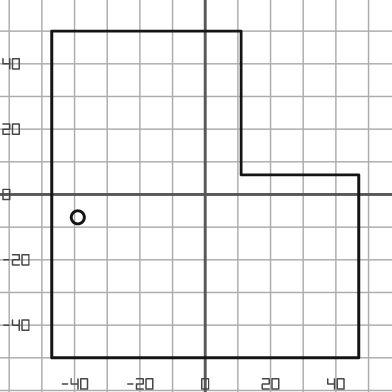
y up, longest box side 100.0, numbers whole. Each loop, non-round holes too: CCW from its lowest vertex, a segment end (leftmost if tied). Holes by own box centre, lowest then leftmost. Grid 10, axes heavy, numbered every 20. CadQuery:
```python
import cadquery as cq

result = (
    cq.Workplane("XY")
    .moveTo(-47.0, -50.0)
    .lineTo(47.0, -50.0)
    .lineTo(47.0, 6.0)
    .lineTo(11.0, 6.0)
    .lineTo(11.0, 50.0)
    .lineTo(-47.0, 50.0)
    .close()
    .moveTo(-39.0, -7.0)
    .circle(2.0)
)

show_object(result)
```